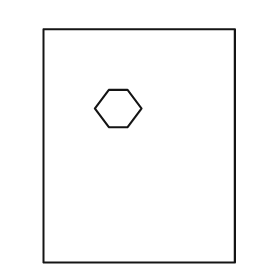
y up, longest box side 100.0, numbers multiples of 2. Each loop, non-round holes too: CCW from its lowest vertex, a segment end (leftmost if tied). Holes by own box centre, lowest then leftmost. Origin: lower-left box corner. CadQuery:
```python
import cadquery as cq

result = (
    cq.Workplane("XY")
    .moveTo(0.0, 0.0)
    .lineTo(82.0, 0.0)
    .lineTo(82.0, 100.0)
    .lineTo(0.0, 100.0)
    .close()
    .moveTo(28.0, 58.0)
    .lineTo(36.0, 58.0)
    .lineTo(42.0, 66.0)
    .lineTo(36.0, 74.0)
    .lineTo(28.0, 74.0)
    .lineTo(22.0, 66.0)
    .close()
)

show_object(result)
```